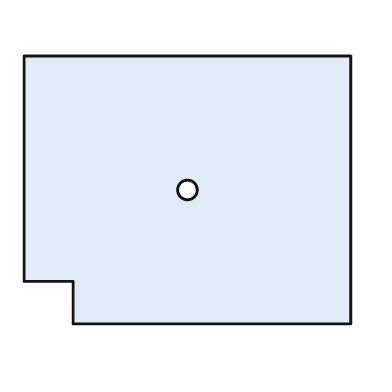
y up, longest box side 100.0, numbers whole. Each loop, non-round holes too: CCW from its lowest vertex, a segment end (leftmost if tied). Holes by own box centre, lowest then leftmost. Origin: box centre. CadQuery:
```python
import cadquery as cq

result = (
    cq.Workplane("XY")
    .moveTo(-35.0, -41.0)
    .lineTo(50.0, -41.0)
    .lineTo(50.0, 41.0)
    .lineTo(-50.0, 41.0)
    .lineTo(-50.0, -28.0)
    .lineTo(-35.0, -28.0)
    .close()
    .moveTo(0.0, 0.0)
    .circle(3.0)
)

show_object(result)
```